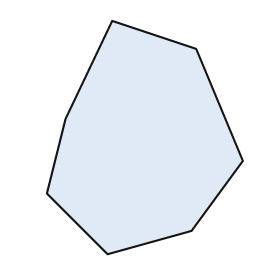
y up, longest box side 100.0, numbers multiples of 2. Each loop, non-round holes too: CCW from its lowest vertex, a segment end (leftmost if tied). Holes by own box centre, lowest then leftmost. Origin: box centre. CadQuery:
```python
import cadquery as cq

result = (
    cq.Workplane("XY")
    .moveTo(-16.0, -50.0)
    .lineTo(20.0, -40.0)
    .lineTo(42.0, -10.0)
    .lineTo(22.0, 38.0)
    .lineTo(-14.0, 50.0)
    .lineTo(-34.0, 8.0)
    .lineTo(-42.0, -24.0)
    .close()
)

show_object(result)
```